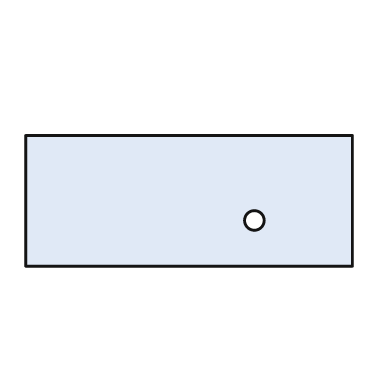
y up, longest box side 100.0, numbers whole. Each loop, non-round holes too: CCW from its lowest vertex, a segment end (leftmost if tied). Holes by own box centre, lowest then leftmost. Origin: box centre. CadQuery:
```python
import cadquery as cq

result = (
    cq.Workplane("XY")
    .moveTo(-50.0, -20.0)
    .lineTo(50.0, -20.0)
    .lineTo(50.0, 20.0)
    .lineTo(-50.0, 20.0)
    .close()
    .moveTo(20.0, -6.0)
    .circle(3.0)
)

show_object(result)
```